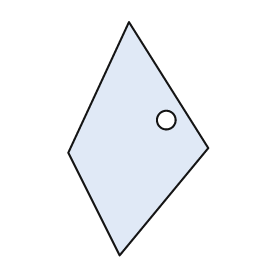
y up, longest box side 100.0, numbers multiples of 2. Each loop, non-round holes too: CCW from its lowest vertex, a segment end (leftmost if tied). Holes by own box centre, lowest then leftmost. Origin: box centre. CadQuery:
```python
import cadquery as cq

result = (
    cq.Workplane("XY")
    .moveTo(-8.0, -50.0)
    .lineTo(30.0, -4.0)
    .lineTo(-4.0, 50.0)
    .lineTo(-30.0, -6.0)
    .close()
    .moveTo(12.0, 8.0)
    .circle(4.0)
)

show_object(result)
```